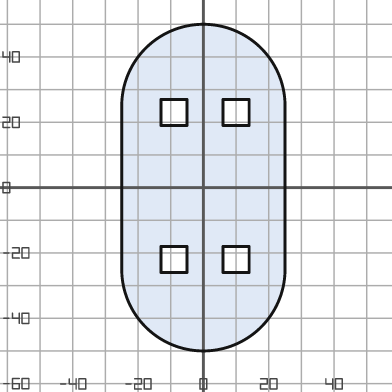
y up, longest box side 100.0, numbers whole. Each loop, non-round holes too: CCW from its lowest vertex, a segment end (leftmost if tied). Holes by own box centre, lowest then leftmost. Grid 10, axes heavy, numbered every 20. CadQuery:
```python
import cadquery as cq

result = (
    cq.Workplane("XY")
    .moveTo(-25.0, -25.0)
    .threePointArc((0.0, -50.0), (25.0, -25.0))
    .lineTo(25.0, 25.0)
    .threePointArc((0.0, 50.0), (-25.0, 25.0))
    .close()
    .moveTo(-13.0, -26.0)
    .lineTo(-5.0, -26.0)
    .lineTo(-5.0, -18.0)
    .lineTo(-13.0, -18.0)
    .close()
    .moveTo(6.0, -26.0)
    .lineTo(14.0, -26.0)
    .lineTo(14.0, -18.0)
    .lineTo(6.0, -18.0)
    .close()
    .moveTo(-13.0, 19.0)
    .lineTo(-5.0, 19.0)
    .lineTo(-5.0, 27.0)
    .lineTo(-13.0, 27.0)
    .close()
    .moveTo(6.0, 19.0)
    .lineTo(14.0, 19.0)
    .lineTo(14.0, 27.0)
    .lineTo(6.0, 27.0)
    .close()
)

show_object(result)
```